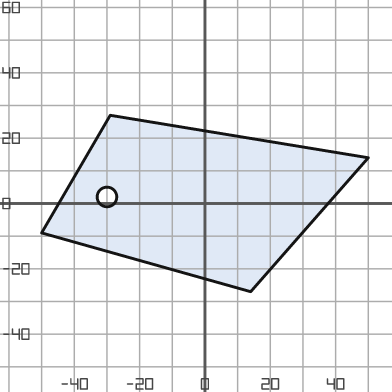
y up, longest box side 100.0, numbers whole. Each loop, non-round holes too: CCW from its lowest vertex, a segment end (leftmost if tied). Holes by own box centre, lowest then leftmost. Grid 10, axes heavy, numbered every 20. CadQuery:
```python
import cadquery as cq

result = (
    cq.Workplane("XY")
    .moveTo(14.0, -27.0)
    .lineTo(50.0, 14.0)
    .lineTo(-29.0, 27.0)
    .lineTo(-50.0, -9.0)
    .close()
    .moveTo(-30.0, 2.0)
    .circle(3.0)
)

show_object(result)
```